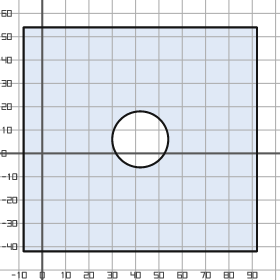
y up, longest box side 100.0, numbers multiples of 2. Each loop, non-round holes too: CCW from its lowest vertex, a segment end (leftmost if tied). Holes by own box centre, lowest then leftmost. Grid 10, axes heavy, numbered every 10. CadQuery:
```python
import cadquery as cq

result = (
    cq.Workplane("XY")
    .moveTo(-8.0, -42.0)
    .lineTo(92.0, -42.0)
    .lineTo(92.0, 54.0)
    .lineTo(-8.0, 54.0)
    .close()
    .moveTo(42.0, 6.0)
    .circle(12.0)
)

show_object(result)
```